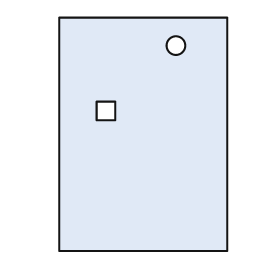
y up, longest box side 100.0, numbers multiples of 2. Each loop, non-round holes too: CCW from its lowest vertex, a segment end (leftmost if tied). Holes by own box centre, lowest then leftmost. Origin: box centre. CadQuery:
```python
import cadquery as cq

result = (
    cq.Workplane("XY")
    .moveTo(-36.0, -50.0)
    .lineTo(36.0, -50.0)
    .lineTo(36.0, 50.0)
    .lineTo(-36.0, 50.0)
    .close()
    .moveTo(-20.0, 6.0)
    .lineTo(-12.0, 6.0)
    .lineTo(-12.0, 14.0)
    .lineTo(-20.0, 14.0)
    .close()
    .moveTo(14.0, 38.0)
    .circle(4.0)
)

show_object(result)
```